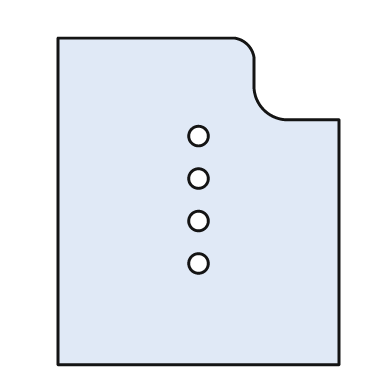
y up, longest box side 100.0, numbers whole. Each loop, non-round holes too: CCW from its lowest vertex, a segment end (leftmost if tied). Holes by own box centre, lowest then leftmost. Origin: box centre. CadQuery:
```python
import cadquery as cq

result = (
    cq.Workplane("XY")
    .moveTo(-43.0, -50.0)
    .lineTo(43.0, -50.0)
    .lineTo(43.0, 25.0)
    .lineTo(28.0, 25.0)
    .threePointArc((20.0, 28.0), (17.0, 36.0))
    .lineTo(17.0, 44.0)
    .threePointArc((15.0, 48.0), (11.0, 50.0))
    .lineTo(-43.0, 50.0)
    .close()
    .moveTo(0.0, -19.0)
    .circle(3.0)
    .moveTo(0.0, -6.0)
    .circle(3.0)
    .moveTo(0.0, 7.0)
    .circle(3.0)
    .moveTo(0.0, 20.0)
    .circle(3.0)
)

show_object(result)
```